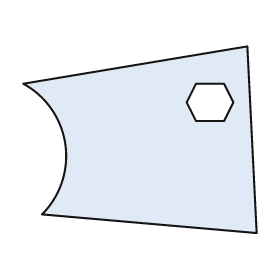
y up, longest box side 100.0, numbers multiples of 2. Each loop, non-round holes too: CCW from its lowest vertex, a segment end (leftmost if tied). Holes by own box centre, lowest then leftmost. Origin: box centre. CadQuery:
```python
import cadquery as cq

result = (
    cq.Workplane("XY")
    .moveTo(50.0, -40.0)
    .lineTo(46.0, 40.0)
    .lineTo(-50.0, 24.0)
    .threePointArc((-32.0, -2.0), (-42.0, -32.0))
    .close()
    .moveTo(24.0, 8.0)
    .lineTo(36.0, 8.0)
    .lineTo(40.0, 16.0)
    .lineTo(36.0, 24.0)
    .lineTo(24.0, 24.0)
    .lineTo(20.0, 16.0)
    .close()
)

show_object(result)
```